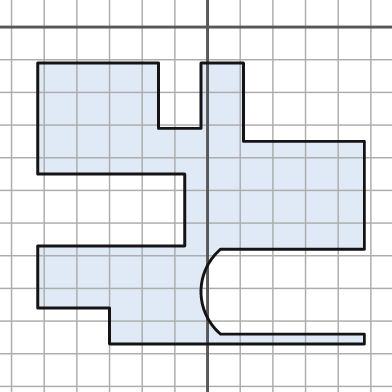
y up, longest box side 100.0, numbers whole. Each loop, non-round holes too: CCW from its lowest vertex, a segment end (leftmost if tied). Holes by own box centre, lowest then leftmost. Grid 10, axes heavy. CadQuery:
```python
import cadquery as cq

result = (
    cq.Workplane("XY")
    .moveTo(-30.0, -97.0)
    .lineTo(48.0, -97.0)
    .lineTo(48.0, -94.0)
    .lineTo(4.0, -94.0)
    .threePointArc((-2.0, -81.0), (4.0, -68.0))
    .lineTo(48.0, -68.0)
    .lineTo(48.0, -35.0)
    .lineTo(11.0, -35.0)
    .lineTo(11.0, -11.0)
    .lineTo(-2.0, -11.0)
    .lineTo(-2.0, -31.0)
    .lineTo(-15.0, -31.0)
    .lineTo(-15.0, -11.0)
    .lineTo(-52.0, -11.0)
    .lineTo(-52.0, -45.0)
    .lineTo(-7.0, -45.0)
    .lineTo(-7.0, -67.0)
    .lineTo(-52.0, -67.0)
    .lineTo(-52.0, -86.0)
    .lineTo(-30.0, -86.0)
    .close()
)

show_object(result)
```